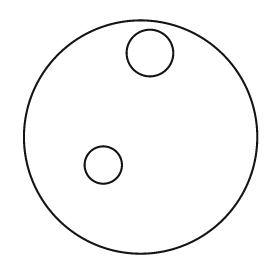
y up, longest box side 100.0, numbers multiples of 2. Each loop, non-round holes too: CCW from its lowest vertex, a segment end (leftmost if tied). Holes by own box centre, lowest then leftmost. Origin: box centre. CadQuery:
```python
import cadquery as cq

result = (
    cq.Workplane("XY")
    .moveTo(0.0, 0.0)
    .circle(50.0)
    .moveTo(-16.0, -12.0)
    .circle(8.0)
    .moveTo(4.0, 36.0)
    .circle(10.0)
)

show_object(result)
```